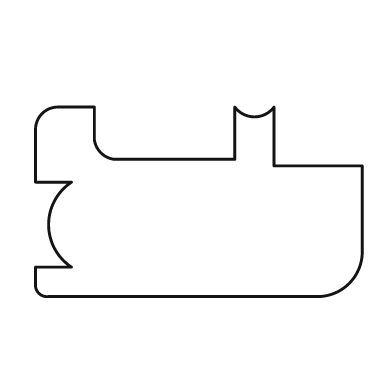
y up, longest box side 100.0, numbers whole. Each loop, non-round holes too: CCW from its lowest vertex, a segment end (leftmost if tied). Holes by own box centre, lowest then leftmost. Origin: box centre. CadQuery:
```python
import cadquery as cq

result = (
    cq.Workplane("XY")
    .moveTo(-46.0, -29.0)
    .lineTo(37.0, -29.0)
    .threePointArc((46.0, -25.0), (50.0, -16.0))
    .lineTo(50.0, 11.0)
    .lineTo(23.0, 11.0)
    .lineTo(23.0, 29.0)
    .threePointArc((17.0, 26.0), (11.0, 29.0))
    .lineTo(11.0, 13.0)
    .lineTo(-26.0, 13.0)
    .threePointArc((-30.0, 15.0), (-32.0, 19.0))
    .lineTo(-32.0, 29.0)
    .lineTo(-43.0, 29.0)
    .threePointArc((-48.0, 27.0), (-50.0, 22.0))
    .lineTo(-50.0, 6.0)
    .lineTo(-39.0, 6.0)
    .threePointArc((-46.0, -7.0), (-39.0, -20.0))
    .lineTo(-50.0, -20.0)
    .lineTo(-50.0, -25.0)
    .threePointArc((-49.0, -28.0), (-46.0, -29.0))
    .close()
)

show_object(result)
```